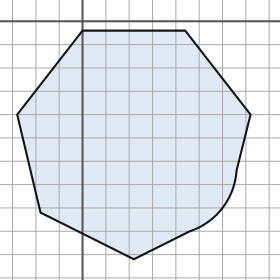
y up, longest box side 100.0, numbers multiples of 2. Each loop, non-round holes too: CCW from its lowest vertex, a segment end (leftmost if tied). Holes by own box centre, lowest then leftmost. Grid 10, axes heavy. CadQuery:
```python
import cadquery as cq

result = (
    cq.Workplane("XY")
    .moveTo(22.0, -102.0)
    .lineTo(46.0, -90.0)
    .threePointArc((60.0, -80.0), (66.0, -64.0))
    .lineTo(72.0, -40.0)
    .lineTo(44.0, -4.0)
    .lineTo(0.0, -4.0)
    .lineTo(-28.0, -40.0)
    .lineTo(-18.0, -82.0)
    .close()
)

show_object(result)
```